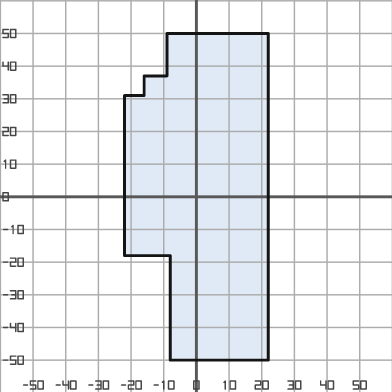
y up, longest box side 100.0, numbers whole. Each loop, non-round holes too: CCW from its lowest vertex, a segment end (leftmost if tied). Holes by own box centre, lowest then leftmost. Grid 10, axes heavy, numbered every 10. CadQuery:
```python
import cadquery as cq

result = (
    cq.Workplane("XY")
    .moveTo(-8.0, -50.0)
    .lineTo(22.0, -50.0)
    .lineTo(22.0, 50.0)
    .lineTo(-9.0, 50.0)
    .lineTo(-9.0, 37.0)
    .lineTo(-16.0, 37.0)
    .lineTo(-16.0, 31.0)
    .lineTo(-22.0, 31.0)
    .lineTo(-22.0, -18.0)
    .lineTo(-8.0, -18.0)
    .close()
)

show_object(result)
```